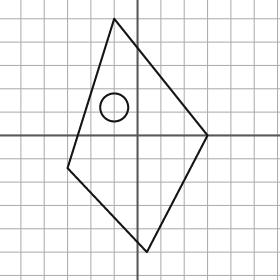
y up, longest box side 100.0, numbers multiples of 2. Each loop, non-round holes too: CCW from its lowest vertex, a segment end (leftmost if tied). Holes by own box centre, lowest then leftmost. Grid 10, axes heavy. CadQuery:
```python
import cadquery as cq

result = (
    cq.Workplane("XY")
    .moveTo(4.0, -50.0)
    .lineTo(30.0, 0.0)
    .lineTo(-10.0, 50.0)
    .lineTo(-30.0, -14.0)
    .close()
    .moveTo(-10.0, 12.0)
    .circle(6.0)
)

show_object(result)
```